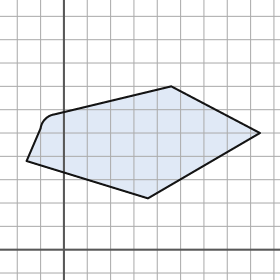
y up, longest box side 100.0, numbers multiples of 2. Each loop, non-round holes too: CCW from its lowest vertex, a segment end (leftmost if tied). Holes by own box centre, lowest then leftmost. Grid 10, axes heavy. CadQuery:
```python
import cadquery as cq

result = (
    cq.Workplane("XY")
    .moveTo(36.0, 22.0)
    .lineTo(84.0, 50.0)
    .lineTo(46.0, 70.0)
    .lineTo(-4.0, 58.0)
    .threePointArc((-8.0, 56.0), (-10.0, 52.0))
    .lineTo(-16.0, 38.0)
    .close()
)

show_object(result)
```